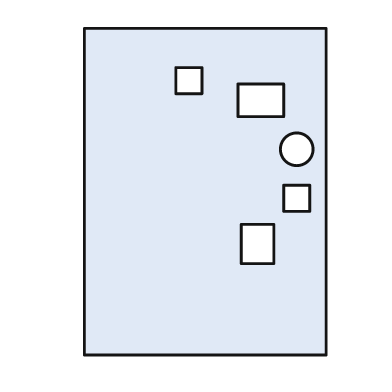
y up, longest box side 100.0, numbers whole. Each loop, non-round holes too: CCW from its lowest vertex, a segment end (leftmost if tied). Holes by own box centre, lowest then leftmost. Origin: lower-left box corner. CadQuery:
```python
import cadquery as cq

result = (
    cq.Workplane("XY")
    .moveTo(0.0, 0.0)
    .lineTo(74.0, 0.0)
    .lineTo(74.0, 100.0)
    .lineTo(0.0, 100.0)
    .close()
    .moveTo(48.0, 28.0)
    .lineTo(58.0, 28.0)
    .lineTo(58.0, 40.0)
    .lineTo(48.0, 40.0)
    .close()
    .moveTo(61.0, 44.0)
    .lineTo(69.0, 44.0)
    .lineTo(69.0, 52.0)
    .lineTo(61.0, 52.0)
    .close()
    .moveTo(65.0, 63.0)
    .circle(5.0)
    .moveTo(47.0, 73.0)
    .lineTo(61.0, 73.0)
    .lineTo(61.0, 83.0)
    .lineTo(47.0, 83.0)
    .close()
    .moveTo(28.0, 80.0)
    .lineTo(36.0, 80.0)
    .lineTo(36.0, 88.0)
    .lineTo(28.0, 88.0)
    .close()
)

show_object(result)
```